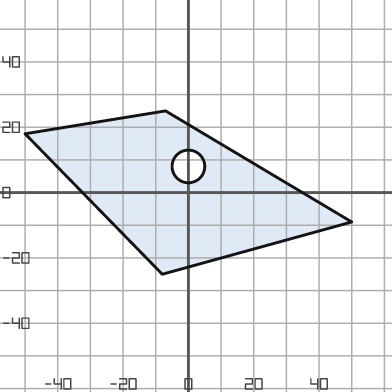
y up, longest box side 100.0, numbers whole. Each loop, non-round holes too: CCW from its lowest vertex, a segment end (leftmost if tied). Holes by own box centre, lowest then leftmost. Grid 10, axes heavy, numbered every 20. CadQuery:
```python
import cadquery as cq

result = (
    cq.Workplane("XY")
    .moveTo(-8.0, -25.0)
    .lineTo(50.0, -9.0)
    .lineTo(-7.0, 25.0)
    .lineTo(-50.0, 18.0)
    .close()
    .moveTo(0.0, 8.0)
    .circle(5.0)
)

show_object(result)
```